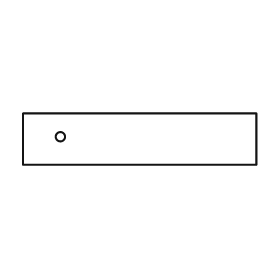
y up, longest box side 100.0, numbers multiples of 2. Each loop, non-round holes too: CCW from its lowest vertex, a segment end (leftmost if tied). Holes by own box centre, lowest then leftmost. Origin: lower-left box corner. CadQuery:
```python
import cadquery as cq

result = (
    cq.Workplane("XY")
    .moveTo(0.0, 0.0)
    .lineTo(100.0, 0.0)
    .lineTo(100.0, 22.0)
    .lineTo(0.0, 22.0)
    .close()
    .moveTo(16.0, 12.0)
    .circle(2.0)
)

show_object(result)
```